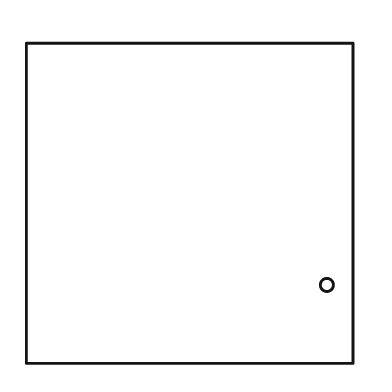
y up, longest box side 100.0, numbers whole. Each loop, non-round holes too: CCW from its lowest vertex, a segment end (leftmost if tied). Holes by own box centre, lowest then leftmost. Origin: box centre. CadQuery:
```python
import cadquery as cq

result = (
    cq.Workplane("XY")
    .moveTo(-50.0, -49.0)
    .lineTo(50.0, -49.0)
    .lineTo(50.0, 49.0)
    .lineTo(-50.0, 49.0)
    .close()
    .moveTo(42.0, -25.0)
    .circle(2.0)
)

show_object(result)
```